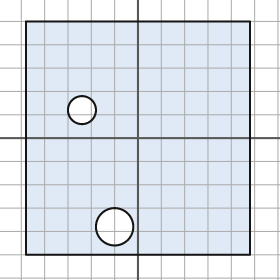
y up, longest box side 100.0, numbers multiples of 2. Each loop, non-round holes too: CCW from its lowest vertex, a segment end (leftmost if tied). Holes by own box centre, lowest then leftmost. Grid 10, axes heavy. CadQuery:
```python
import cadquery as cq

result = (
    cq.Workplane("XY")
    .moveTo(-48.0, -50.0)
    .lineTo(48.0, -50.0)
    .lineTo(48.0, 50.0)
    .lineTo(-48.0, 50.0)
    .close()
    .moveTo(-10.0, -38.0)
    .circle(8.0)
    .moveTo(-24.0, 12.0)
    .circle(6.0)
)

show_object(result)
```